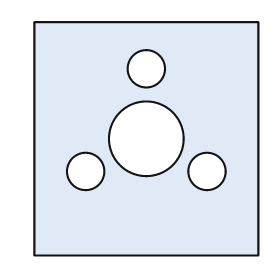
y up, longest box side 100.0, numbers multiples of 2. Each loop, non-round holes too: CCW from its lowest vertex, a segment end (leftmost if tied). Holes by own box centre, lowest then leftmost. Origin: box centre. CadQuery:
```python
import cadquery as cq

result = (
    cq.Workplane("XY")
    .moveTo(-48.0, -50.0)
    .lineTo(48.0, -50.0)
    .lineTo(48.0, 50.0)
    .lineTo(-48.0, 50.0)
    .close()
    .moveTo(-26.0, -14.0)
    .circle(8.0)
    .moveTo(26.0, -14.0)
    .circle(8.0)
    .moveTo(0.0, 0.0)
    .circle(16.0)
    .moveTo(0.0, 30.0)
    .circle(8.0)
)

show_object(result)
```